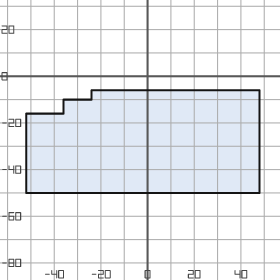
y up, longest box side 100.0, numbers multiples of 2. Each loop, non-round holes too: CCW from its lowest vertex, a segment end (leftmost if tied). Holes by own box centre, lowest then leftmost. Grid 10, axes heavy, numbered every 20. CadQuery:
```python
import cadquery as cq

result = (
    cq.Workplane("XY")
    .moveTo(-52.0, -50.0)
    .lineTo(48.0, -50.0)
    .lineTo(48.0, -6.0)
    .lineTo(-24.0, -6.0)
    .lineTo(-24.0, -10.0)
    .lineTo(-36.0, -10.0)
    .lineTo(-36.0, -16.0)
    .lineTo(-52.0, -16.0)
    .close()
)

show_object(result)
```